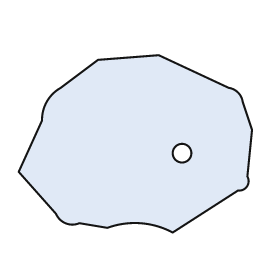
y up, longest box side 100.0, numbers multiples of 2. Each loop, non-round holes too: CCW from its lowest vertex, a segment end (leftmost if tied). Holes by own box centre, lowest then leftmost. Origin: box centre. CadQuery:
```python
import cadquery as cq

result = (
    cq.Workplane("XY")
    .moveTo(16.0, -38.0)
    .lineTo(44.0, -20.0)
    .threePointArc((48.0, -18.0), (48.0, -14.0))
    .lineTo(50.0, 6.0)
    .lineTo(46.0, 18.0)
    .threePointArc((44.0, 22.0), (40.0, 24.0))
    .lineTo(10.0, 38.0)
    .lineTo(-16.0, 36.0)
    .lineTo(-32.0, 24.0)
    .threePointArc((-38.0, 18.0), (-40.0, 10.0))
    .lineTo(-50.0, -12.0)
    .lineTo(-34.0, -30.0)
    .threePointArc((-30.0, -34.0), (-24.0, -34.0))
    .lineTo(-12.0, -36.0)
    .threePointArc((2.0, -34.0), (16.0, -38.0))
    .close()
    .moveTo(20.0, -4.0)
    .circle(4.0)
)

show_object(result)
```